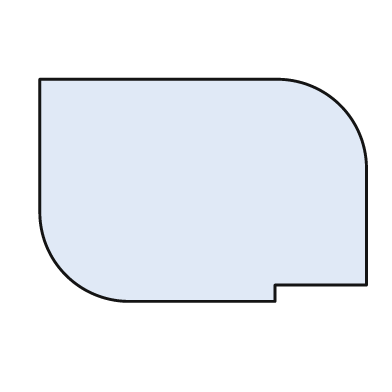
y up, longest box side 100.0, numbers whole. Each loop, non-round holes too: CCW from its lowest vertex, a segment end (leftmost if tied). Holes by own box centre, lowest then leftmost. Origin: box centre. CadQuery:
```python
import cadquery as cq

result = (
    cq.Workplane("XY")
    .moveTo(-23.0, -34.0)
    .lineTo(22.0, -34.0)
    .lineTo(22.0, -29.0)
    .lineTo(50.0, -29.0)
    .lineTo(50.0, 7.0)
    .threePointArc((42.0, 26.0), (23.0, 34.0))
    .lineTo(-50.0, 34.0)
    .lineTo(-50.0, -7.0)
    .threePointArc((-42.0, -26.0), (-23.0, -34.0))
    .close()
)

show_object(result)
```